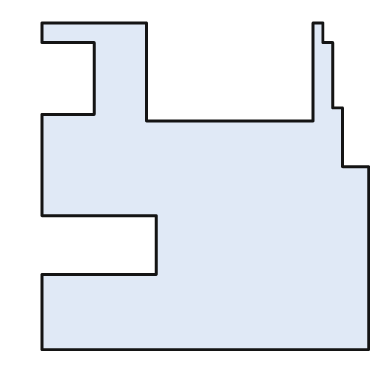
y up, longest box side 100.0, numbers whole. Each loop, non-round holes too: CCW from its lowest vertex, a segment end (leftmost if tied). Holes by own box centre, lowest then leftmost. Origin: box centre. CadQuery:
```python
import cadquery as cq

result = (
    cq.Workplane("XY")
    .moveTo(-50.0, -50.0)
    .lineTo(50.0, -50.0)
    .lineTo(50.0, 6.0)
    .lineTo(42.0, 6.0)
    .lineTo(42.0, 24.0)
    .lineTo(39.0, 24.0)
    .lineTo(39.0, 44.0)
    .lineTo(36.0, 44.0)
    .lineTo(36.0, 50.0)
    .lineTo(33.0, 50.0)
    .lineTo(33.0, 20.0)
    .lineTo(-18.0, 20.0)
    .lineTo(-18.0, 50.0)
    .lineTo(-50.0, 50.0)
    .lineTo(-50.0, 44.0)
    .lineTo(-34.0, 44.0)
    .lineTo(-34.0, 22.0)
    .lineTo(-50.0, 22.0)
    .lineTo(-50.0, -9.0)
    .lineTo(-15.0, -9.0)
    .lineTo(-15.0, -27.0)
    .lineTo(-50.0, -27.0)
    .close()
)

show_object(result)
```